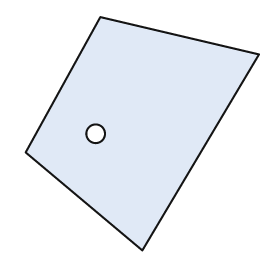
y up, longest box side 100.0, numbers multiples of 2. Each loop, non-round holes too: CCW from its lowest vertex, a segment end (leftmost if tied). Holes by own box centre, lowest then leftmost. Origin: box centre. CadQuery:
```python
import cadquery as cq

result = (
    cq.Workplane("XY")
    .moveTo(0.0, -50.0)
    .lineTo(50.0, 34.0)
    .lineTo(-18.0, 50.0)
    .lineTo(-50.0, -8.0)
    .close()
    .moveTo(-20.0, 0.0)
    .circle(4.0)
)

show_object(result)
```